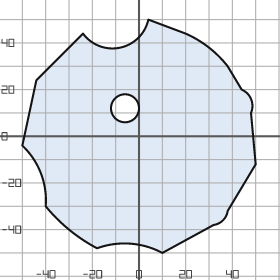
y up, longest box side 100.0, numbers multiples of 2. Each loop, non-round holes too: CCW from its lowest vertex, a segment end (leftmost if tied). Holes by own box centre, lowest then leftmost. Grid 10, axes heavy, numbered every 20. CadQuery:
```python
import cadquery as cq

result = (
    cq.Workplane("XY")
    .moveTo(10.0, -50.0)
    .lineTo(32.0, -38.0)
    .threePointArc((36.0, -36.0), (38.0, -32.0))
    .lineTo(50.0, -12.0)
    .lineTo(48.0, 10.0)
    .threePointArc((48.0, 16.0), (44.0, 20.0))
    .lineTo(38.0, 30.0)
    .threePointArc((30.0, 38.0), (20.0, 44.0))
    .lineTo(4.0, 50.0)
    .threePointArc((-8.0, 38.0), (-24.0, 44.0))
    .lineTo(-44.0, 24.0)
    .lineTo(-50.0, -4.0)
    .threePointArc((-42.0, -16.0), (-40.0, -30.0))
    .threePointArc((-30.0, -40.0), (-18.0, -48.0))
    .threePointArc((-4.0, -46.0), (10.0, -50.0))
    .close()
    .moveTo(-6.0, 12.0)
    .circle(6.0)
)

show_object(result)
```